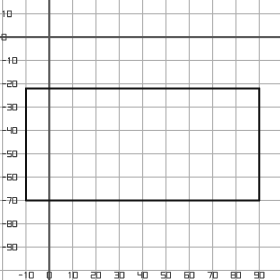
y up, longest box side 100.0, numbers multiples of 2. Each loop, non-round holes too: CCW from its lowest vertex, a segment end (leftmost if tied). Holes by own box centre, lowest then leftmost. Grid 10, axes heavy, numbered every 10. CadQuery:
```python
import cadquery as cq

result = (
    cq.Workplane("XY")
    .moveTo(-10.0, -70.0)
    .lineTo(90.0, -70.0)
    .lineTo(90.0, -22.0)
    .lineTo(-10.0, -22.0)
    .close()
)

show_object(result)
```